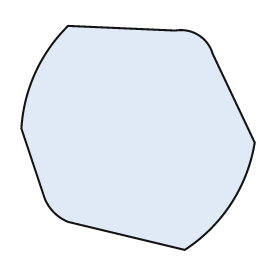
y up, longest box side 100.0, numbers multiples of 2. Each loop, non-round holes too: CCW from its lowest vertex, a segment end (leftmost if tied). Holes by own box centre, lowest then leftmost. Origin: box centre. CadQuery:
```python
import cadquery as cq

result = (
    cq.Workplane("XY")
    .moveTo(20.0, -48.0)
    .threePointArc((40.0, -28.0), (50.0, -2.0))
    .lineTo(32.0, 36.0)
    .threePointArc((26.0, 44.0), (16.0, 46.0))
    .lineTo(-30.0, 48.0)
    .threePointArc((-44.0, 28.0), (-50.0, 4.0))
    .lineTo(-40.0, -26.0)
    .threePointArc((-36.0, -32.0), (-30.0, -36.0))
    .close()
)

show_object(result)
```